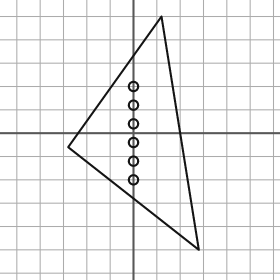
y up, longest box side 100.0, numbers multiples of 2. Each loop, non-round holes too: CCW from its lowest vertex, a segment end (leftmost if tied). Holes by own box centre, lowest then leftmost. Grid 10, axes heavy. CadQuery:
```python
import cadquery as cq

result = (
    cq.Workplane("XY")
    .moveTo(28.0, -50.0)
    .lineTo(12.0, 50.0)
    .lineTo(-28.0, -6.0)
    .close()
    .moveTo(0.0, -20.0)
    .circle(2.0)
    .moveTo(0.0, -12.0)
    .circle(2.0)
    .moveTo(0.0, -4.0)
    .circle(2.0)
    .moveTo(0.0, 4.0)
    .circle(2.0)
    .moveTo(0.0, 12.0)
    .circle(2.0)
    .moveTo(0.0, 20.0)
    .circle(2.0)
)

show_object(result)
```